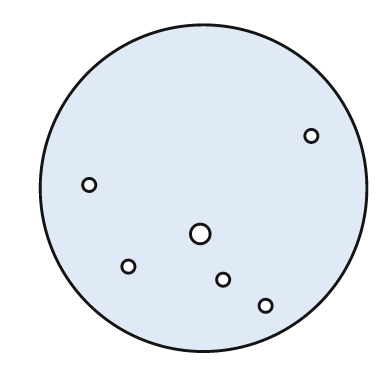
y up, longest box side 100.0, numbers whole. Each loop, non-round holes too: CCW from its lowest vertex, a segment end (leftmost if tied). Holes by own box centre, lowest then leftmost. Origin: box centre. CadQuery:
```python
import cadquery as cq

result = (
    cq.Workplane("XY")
    .moveTo(0.0, 0.0)
    .circle(50.0)
    .moveTo(19.0, -36.0)
    .circle(2.0)
    .moveTo(6.0, -28.0)
    .circle(2.0)
    .moveTo(-23.0, -24.0)
    .circle(2.0)
    .moveTo(-1.0, -14.0)
    .circle(3.0)
    .moveTo(-35.0, 1.0)
    .circle(2.0)
    .moveTo(33.0, 16.0)
    .circle(2.0)
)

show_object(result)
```